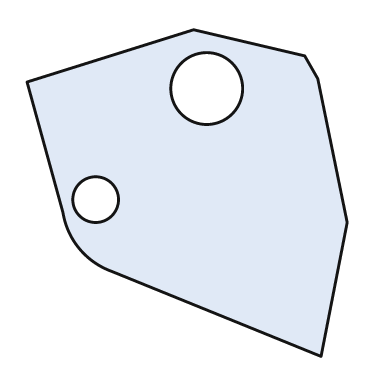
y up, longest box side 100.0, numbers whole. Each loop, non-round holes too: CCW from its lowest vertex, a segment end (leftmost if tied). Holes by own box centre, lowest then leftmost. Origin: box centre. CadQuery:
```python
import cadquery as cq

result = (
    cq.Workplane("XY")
    .moveTo(41.0, -50.0)
    .lineTo(49.0, -9.0)
    .lineTo(40.0, 35.0)
    .lineTo(36.0, 42.0)
    .lineTo(2.0, 50.0)
    .lineTo(-49.0, 34.0)
    .lineTo(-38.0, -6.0)
    .threePointArc((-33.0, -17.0), (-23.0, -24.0))
    .close()
    .moveTo(-28.0, -2.0)
    .circle(7.0)
    .moveTo(6.0, 32.0)
    .circle(11.0)
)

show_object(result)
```